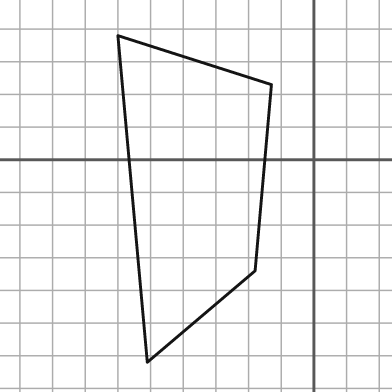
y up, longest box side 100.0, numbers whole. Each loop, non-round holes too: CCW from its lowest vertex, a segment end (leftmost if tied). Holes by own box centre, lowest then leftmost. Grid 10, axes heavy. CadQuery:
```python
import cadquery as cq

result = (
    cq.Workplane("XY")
    .moveTo(-51.0, -62.0)
    .lineTo(-18.0, -34.0)
    .lineTo(-13.0, 23.0)
    .lineTo(-60.0, 38.0)
    .close()
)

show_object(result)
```